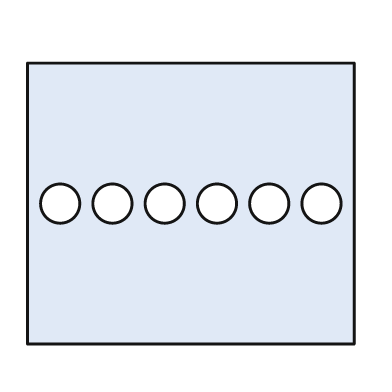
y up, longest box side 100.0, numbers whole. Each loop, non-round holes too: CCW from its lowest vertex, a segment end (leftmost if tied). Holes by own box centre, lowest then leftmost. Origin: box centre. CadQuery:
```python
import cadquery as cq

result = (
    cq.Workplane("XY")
    .moveTo(-50.0, -43.0)
    .lineTo(50.0, -43.0)
    .lineTo(50.0, 43.0)
    .lineTo(-50.0, 43.0)
    .close()
    .moveTo(-40.0, 0.0)
    .circle(6.0)
    .moveTo(-24.0, 0.0)
    .circle(6.0)
    .moveTo(-8.0, 0.0)
    .circle(6.0)
    .moveTo(8.0, 0.0)
    .circle(6.0)
    .moveTo(24.0, 0.0)
    .circle(6.0)
    .moveTo(40.0, 0.0)
    .circle(6.0)
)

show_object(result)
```